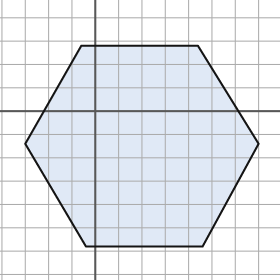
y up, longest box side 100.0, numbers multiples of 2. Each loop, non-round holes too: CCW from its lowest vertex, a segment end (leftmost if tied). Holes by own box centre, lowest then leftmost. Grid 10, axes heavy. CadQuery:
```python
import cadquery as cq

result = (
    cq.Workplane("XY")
    .moveTo(-4.0, -58.0)
    .lineTo(46.0, -58.0)
    .lineTo(70.0, -14.0)
    .lineTo(44.0, 28.0)
    .lineTo(-6.0, 28.0)
    .lineTo(-30.0, -14.0)
    .close()
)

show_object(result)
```